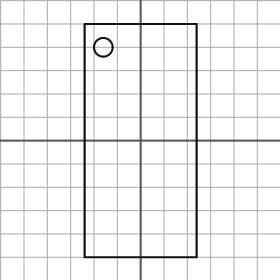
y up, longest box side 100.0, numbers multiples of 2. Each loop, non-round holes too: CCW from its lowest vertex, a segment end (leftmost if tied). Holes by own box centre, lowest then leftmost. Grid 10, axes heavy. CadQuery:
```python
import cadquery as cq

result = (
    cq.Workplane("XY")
    .moveTo(-24.0, -50.0)
    .lineTo(24.0, -50.0)
    .lineTo(24.0, 50.0)
    .lineTo(-24.0, 50.0)
    .close()
    .moveTo(-16.0, 40.0)
    .circle(4.0)
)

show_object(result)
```